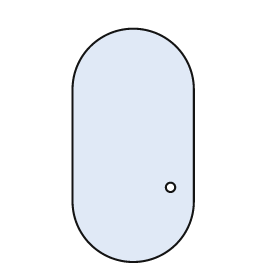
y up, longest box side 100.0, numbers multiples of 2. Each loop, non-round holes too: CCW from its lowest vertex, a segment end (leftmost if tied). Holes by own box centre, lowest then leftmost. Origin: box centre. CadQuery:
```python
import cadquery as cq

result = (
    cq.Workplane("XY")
    .moveTo(-26.0, -24.0)
    .threePointArc((0.0, -50.0), (26.0, -24.0))
    .lineTo(26.0, 24.0)
    .threePointArc((0.0, 50.0), (-26.0, 24.0))
    .close()
    .moveTo(16.0, -18.0)
    .circle(2.0)
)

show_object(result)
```